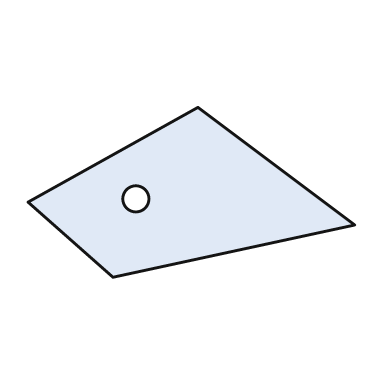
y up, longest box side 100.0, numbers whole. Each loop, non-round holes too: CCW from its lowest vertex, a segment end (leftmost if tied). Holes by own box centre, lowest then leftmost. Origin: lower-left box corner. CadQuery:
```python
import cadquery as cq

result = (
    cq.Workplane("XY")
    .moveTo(26.0, 0.0)
    .lineTo(100.0, 16.0)
    .lineTo(52.0, 52.0)
    .lineTo(0.0, 23.0)
    .close()
    .moveTo(33.0, 24.0)
    .circle(4.0)
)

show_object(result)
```